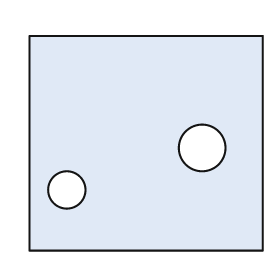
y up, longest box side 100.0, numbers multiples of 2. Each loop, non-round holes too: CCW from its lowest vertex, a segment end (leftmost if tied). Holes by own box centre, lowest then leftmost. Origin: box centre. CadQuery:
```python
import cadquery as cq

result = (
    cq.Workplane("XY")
    .moveTo(-50.0, -46.0)
    .lineTo(50.0, -46.0)
    .lineTo(50.0, 46.0)
    .lineTo(-50.0, 46.0)
    .close()
    .moveTo(-34.0, -20.0)
    .circle(8.0)
    .moveTo(24.0, -2.0)
    .circle(10.0)
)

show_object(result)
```